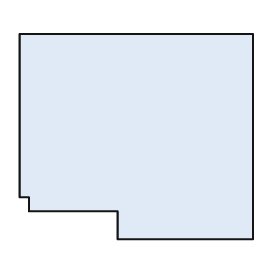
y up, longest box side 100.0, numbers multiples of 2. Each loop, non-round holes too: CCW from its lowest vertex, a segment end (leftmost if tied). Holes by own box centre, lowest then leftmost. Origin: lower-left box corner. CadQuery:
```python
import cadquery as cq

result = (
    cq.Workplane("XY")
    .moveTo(42.0, 0.0)
    .lineTo(100.0, 0.0)
    .lineTo(100.0, 88.0)
    .lineTo(0.0, 88.0)
    .lineTo(0.0, 18.0)
    .lineTo(4.0, 18.0)
    .lineTo(4.0, 12.0)
    .lineTo(42.0, 12.0)
    .close()
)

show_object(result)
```